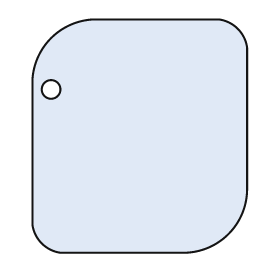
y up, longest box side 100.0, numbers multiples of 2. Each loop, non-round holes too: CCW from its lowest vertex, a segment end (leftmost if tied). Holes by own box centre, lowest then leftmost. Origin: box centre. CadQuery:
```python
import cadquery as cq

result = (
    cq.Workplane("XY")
    .moveTo(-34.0, -50.0)
    .lineTo(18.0, -50.0)
    .threePointArc((38.0, -42.0), (46.0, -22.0))
    .lineTo(46.0, 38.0)
    .threePointArc((42.0, 46.0), (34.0, 50.0))
    .lineTo(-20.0, 50.0)
    .threePointArc((-38.0, 42.0), (-46.0, 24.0))
    .lineTo(-46.0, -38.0)
    .threePointArc((-42.0, -46.0), (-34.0, -50.0))
    .close()
    .moveTo(-38.0, 20.0)
    .circle(4.0)
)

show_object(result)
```